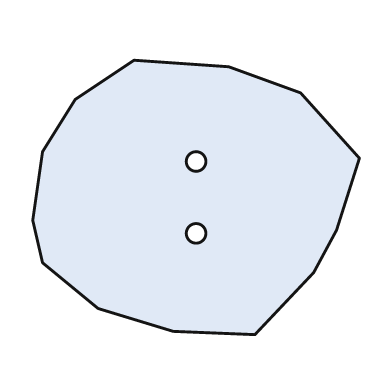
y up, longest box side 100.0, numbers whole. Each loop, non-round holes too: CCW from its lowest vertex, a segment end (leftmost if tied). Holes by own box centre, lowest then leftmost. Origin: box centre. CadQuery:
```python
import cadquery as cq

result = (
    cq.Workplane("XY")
    .moveTo(18.0, -42.0)
    .lineTo(36.0, -23.0)
    .lineTo(43.0, -10.0)
    .lineTo(50.0, 12.0)
    .lineTo(32.0, 32.0)
    .lineTo(10.0, 40.0)
    .lineTo(-19.0, 42.0)
    .lineTo(-37.0, 30.0)
    .lineTo(-47.0, 14.0)
    .lineTo(-50.0, -7.0)
    .lineTo(-47.0, -20.0)
    .lineTo(-30.0, -34.0)
    .lineTo(-7.0, -41.0)
    .close()
    .moveTo(0.0, -11.0)
    .circle(3.0)
    .moveTo(0.0, 11.0)
    .circle(3.0)
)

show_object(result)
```